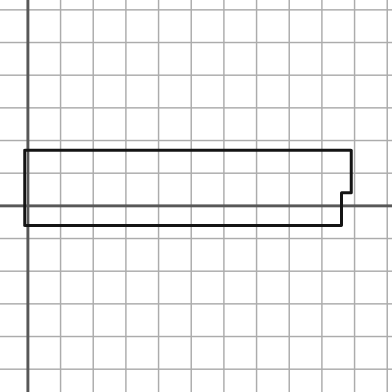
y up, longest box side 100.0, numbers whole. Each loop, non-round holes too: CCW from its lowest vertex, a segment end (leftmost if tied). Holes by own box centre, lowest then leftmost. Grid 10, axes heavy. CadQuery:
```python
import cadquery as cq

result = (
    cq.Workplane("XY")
    .moveTo(-1.0, -6.0)
    .lineTo(96.0, -6.0)
    .lineTo(96.0, 4.0)
    .lineTo(99.0, 4.0)
    .lineTo(99.0, 17.0)
    .lineTo(-1.0, 17.0)
    .close()
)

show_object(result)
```